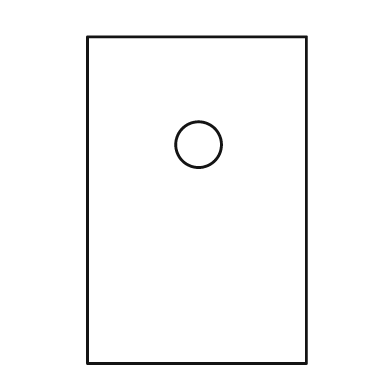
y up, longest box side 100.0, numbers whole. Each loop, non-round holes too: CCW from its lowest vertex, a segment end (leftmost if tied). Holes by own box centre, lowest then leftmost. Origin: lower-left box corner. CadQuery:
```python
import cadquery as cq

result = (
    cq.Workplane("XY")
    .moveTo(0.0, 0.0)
    .lineTo(67.0, 0.0)
    .lineTo(67.0, 100.0)
    .lineTo(0.0, 100.0)
    .close()
    .moveTo(34.0, 67.0)
    .circle(7.0)
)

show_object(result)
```